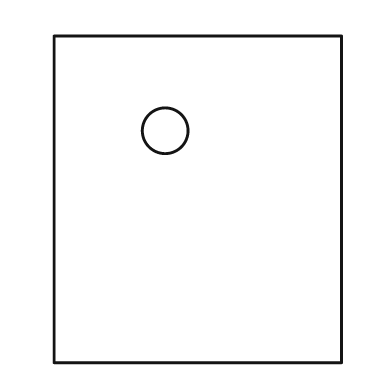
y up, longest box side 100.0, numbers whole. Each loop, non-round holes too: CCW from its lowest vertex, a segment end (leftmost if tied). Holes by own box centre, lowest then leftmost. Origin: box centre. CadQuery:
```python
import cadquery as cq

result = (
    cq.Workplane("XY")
    .moveTo(-44.0, -50.0)
    .lineTo(44.0, -50.0)
    .lineTo(44.0, 50.0)
    .lineTo(-44.0, 50.0)
    .close()
    .moveTo(-10.0, 21.0)
    .circle(7.0)
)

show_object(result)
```